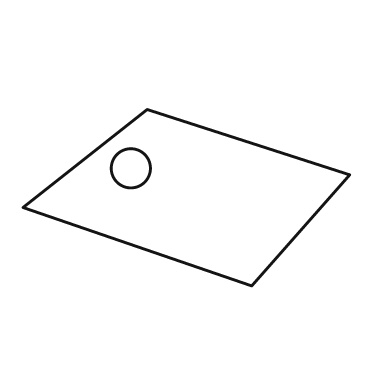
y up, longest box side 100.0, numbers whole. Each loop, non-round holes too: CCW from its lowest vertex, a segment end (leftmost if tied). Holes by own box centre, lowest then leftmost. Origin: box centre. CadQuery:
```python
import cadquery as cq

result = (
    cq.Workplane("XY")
    .moveTo(20.0, -27.0)
    .lineTo(50.0, 7.0)
    .lineTo(-12.0, 27.0)
    .lineTo(-50.0, -3.0)
    .close()
    .moveTo(-17.0, 9.0)
    .circle(6.0)
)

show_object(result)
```